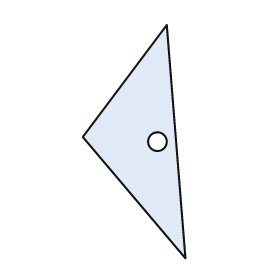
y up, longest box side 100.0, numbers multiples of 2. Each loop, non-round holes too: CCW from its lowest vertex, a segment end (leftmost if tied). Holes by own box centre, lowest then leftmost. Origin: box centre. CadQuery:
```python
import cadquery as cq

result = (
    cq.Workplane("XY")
    .moveTo(22.0, -50.0)
    .lineTo(14.0, 50.0)
    .lineTo(-22.0, 2.0)
    .close()
    .moveTo(10.0, 0.0)
    .circle(4.0)
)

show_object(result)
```